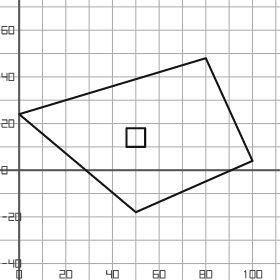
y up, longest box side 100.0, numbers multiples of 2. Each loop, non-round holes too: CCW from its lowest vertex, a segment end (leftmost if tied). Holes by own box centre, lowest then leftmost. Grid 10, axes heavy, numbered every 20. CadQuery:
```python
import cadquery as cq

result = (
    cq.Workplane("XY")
    .moveTo(50.0, -18.0)
    .lineTo(100.0, 4.0)
    .lineTo(80.0, 48.0)
    .lineTo(0.0, 24.0)
    .close()
    .moveTo(46.0, 10.0)
    .lineTo(54.0, 10.0)
    .lineTo(54.0, 18.0)
    .lineTo(46.0, 18.0)
    .close()
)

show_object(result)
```